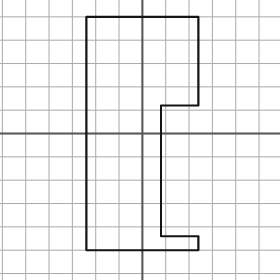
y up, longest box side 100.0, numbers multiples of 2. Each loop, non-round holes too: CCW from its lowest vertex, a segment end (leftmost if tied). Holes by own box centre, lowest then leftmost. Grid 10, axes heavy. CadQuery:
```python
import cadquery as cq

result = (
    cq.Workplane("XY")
    .moveTo(-24.0, -50.0)
    .lineTo(24.0, -50.0)
    .lineTo(24.0, -44.0)
    .lineTo(8.0, -44.0)
    .lineTo(8.0, 12.0)
    .lineTo(24.0, 12.0)
    .lineTo(24.0, 50.0)
    .lineTo(-24.0, 50.0)
    .close()
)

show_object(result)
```